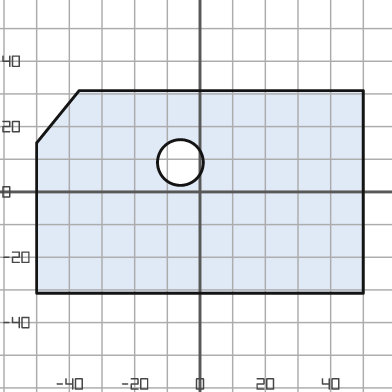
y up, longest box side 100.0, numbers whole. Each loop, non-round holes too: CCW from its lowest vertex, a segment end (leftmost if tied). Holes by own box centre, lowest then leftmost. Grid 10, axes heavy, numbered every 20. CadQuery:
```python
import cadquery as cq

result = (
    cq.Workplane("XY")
    .moveTo(-50.0, -31.0)
    .lineTo(50.0, -31.0)
    .lineTo(50.0, 31.0)
    .lineTo(-37.0, 31.0)
    .lineTo(-50.0, 15.0)
    .close()
    .moveTo(-6.0, 9.0)
    .circle(7.0)
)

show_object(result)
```